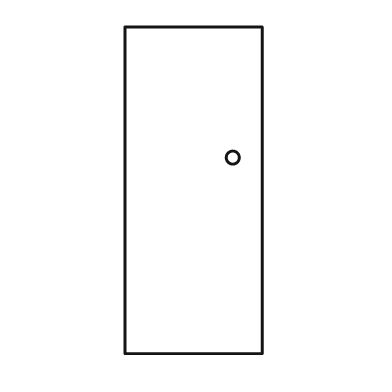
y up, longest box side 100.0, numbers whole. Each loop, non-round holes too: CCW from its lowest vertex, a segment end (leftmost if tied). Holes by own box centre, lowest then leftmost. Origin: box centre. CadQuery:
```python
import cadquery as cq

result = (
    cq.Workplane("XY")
    .moveTo(-21.0, -50.0)
    .lineTo(21.0, -50.0)
    .lineTo(21.0, 50.0)
    .lineTo(-21.0, 50.0)
    .close()
    .moveTo(12.0, 10.0)
    .circle(2.0)
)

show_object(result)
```